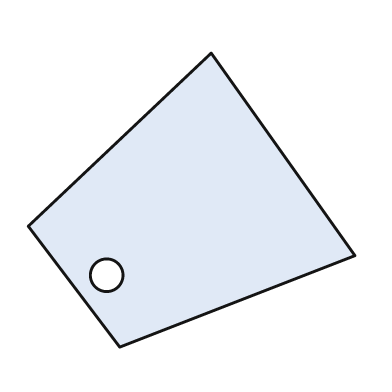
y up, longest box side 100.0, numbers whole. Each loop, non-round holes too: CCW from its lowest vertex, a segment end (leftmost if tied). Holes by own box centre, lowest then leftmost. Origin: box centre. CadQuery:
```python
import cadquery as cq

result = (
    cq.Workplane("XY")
    .moveTo(-22.0, -45.0)
    .lineTo(50.0, -17.0)
    .lineTo(6.0, 45.0)
    .lineTo(-50.0, -8.0)
    .close()
    .moveTo(-26.0, -23.0)
    .circle(5.0)
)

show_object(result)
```